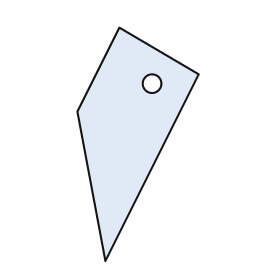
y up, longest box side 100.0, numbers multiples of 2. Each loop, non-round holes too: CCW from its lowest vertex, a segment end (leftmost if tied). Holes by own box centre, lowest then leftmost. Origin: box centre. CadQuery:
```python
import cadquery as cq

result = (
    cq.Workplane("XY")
    .moveTo(-14.0, -50.0)
    .lineTo(26.0, 30.0)
    .lineTo(-8.0, 50.0)
    .lineTo(-26.0, 14.0)
    .close()
    .moveTo(6.0, 26.0)
    .circle(4.0)
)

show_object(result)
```